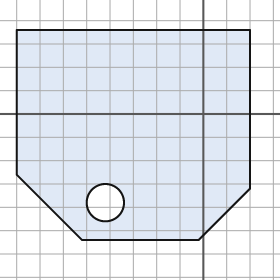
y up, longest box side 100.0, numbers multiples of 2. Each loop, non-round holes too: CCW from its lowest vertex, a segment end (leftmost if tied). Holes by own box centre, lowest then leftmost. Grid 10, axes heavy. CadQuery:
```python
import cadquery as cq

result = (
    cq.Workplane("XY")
    .moveTo(-52.0, -54.0)
    .lineTo(-2.0, -54.0)
    .lineTo(20.0, -32.0)
    .lineTo(20.0, 36.0)
    .lineTo(-80.0, 36.0)
    .lineTo(-80.0, -26.0)
    .close()
    .moveTo(-42.0, -38.0)
    .circle(8.0)
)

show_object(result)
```